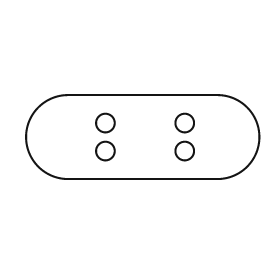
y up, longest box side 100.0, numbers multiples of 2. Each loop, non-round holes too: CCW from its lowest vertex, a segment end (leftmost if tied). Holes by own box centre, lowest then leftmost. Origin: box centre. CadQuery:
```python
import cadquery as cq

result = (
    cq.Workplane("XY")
    .moveTo(-32.0, -18.0)
    .lineTo(32.0, -18.0)
    .threePointArc((50.0, 0.0), (32.0, 18.0))
    .lineTo(-32.0, 18.0)
    .threePointArc((-50.0, 0.0), (-32.0, -18.0))
    .close()
    .moveTo(-16.0, -6.0)
    .circle(4.0)
    .moveTo(18.0, -6.0)
    .circle(4.0)
    .moveTo(-16.0, 6.0)
    .circle(4.0)
    .moveTo(18.0, 6.0)
    .circle(4.0)
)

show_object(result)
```